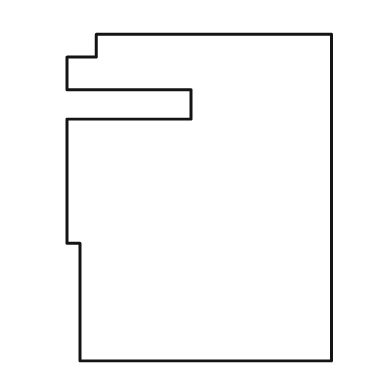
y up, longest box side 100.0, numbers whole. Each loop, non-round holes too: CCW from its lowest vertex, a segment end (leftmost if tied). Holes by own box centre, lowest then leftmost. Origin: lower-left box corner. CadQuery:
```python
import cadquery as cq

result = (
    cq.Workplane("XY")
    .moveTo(4.0, 0.0)
    .lineTo(81.0, 0.0)
    .lineTo(81.0, 100.0)
    .lineTo(9.0, 100.0)
    .lineTo(9.0, 93.0)
    .lineTo(0.0, 93.0)
    .lineTo(0.0, 83.0)
    .lineTo(38.0, 83.0)
    .lineTo(38.0, 74.0)
    .lineTo(0.0, 74.0)
    .lineTo(0.0, 36.0)
    .lineTo(4.0, 36.0)
    .close()
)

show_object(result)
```